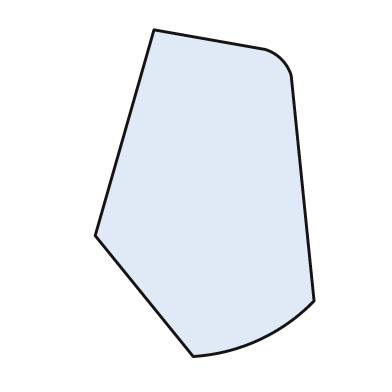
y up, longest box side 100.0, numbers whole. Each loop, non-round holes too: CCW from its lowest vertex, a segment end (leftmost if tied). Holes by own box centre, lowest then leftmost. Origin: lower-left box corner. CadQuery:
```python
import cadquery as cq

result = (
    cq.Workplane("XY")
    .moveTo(30.0, 0.0)
    .threePointArc((50.0, 5.0), (67.0, 17.0))
    .lineTo(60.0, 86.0)
    .threePointArc((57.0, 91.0), (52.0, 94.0))
    .lineTo(18.0, 100.0)
    .lineTo(0.0, 37.0)
    .close()
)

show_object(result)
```